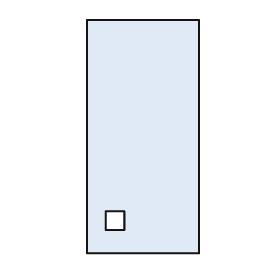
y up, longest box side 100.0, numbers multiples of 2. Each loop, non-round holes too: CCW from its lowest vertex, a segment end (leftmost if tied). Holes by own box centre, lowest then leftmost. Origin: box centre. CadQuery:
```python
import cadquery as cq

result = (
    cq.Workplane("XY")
    .moveTo(-24.0, -50.0)
    .lineTo(24.0, -50.0)
    .lineTo(24.0, 50.0)
    .lineTo(-24.0, 50.0)
    .close()
    .moveTo(-16.0, -40.0)
    .lineTo(-8.0, -40.0)
    .lineTo(-8.0, -32.0)
    .lineTo(-16.0, -32.0)
    .close()
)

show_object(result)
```